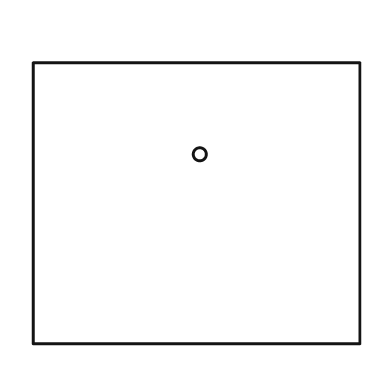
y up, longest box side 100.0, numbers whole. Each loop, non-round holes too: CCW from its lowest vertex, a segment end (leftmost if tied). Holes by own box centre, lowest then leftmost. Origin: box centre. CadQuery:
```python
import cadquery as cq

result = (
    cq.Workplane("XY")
    .moveTo(-50.0, -43.0)
    .lineTo(50.0, -43.0)
    .lineTo(50.0, 43.0)
    .lineTo(-50.0, 43.0)
    .close()
    .moveTo(1.0, 15.0)
    .circle(2.0)
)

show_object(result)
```